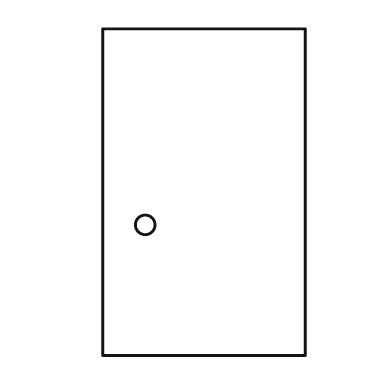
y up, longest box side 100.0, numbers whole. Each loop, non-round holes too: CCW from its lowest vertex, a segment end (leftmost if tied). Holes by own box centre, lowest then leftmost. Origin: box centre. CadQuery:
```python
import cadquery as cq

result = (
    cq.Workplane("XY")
    .moveTo(-31.0, -50.0)
    .lineTo(31.0, -50.0)
    .lineTo(31.0, 50.0)
    .lineTo(-31.0, 50.0)
    .close()
    .moveTo(-18.0, -10.0)
    .circle(3.0)
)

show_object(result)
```